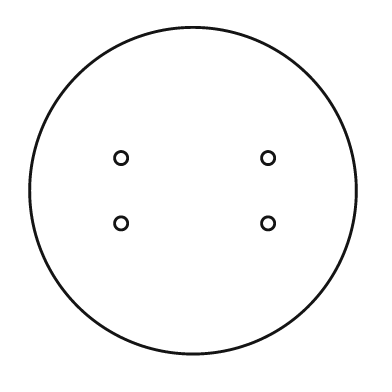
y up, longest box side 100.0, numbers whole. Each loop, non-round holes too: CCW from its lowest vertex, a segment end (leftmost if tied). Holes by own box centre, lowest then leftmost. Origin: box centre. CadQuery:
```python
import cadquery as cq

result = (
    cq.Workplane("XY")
    .moveTo(0.0, 0.0)
    .circle(50.0)
    .moveTo(-22.0, -10.0)
    .circle(2.0)
    .moveTo(23.0, -10.0)
    .circle(2.0)
    .moveTo(-22.0, 10.0)
    .circle(2.0)
    .moveTo(23.0, 10.0)
    .circle(2.0)
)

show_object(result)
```